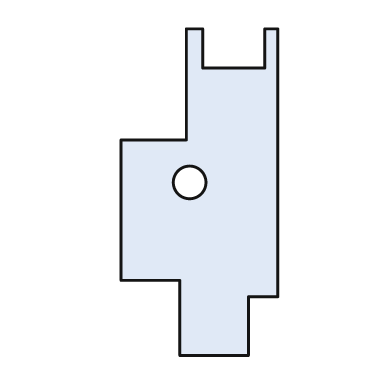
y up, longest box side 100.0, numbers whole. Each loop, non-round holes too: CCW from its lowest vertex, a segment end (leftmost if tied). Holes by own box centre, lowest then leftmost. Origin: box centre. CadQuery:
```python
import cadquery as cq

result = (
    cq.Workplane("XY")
    .moveTo(-6.0, -50.0)
    .lineTo(15.0, -50.0)
    .lineTo(15.0, -32.0)
    .lineTo(24.0, -32.0)
    .lineTo(24.0, 50.0)
    .lineTo(20.0, 50.0)
    .lineTo(20.0, 38.0)
    .lineTo(1.0, 38.0)
    .lineTo(1.0, 50.0)
    .lineTo(-4.0, 50.0)
    .lineTo(-4.0, 16.0)
    .lineTo(-24.0, 16.0)
    .lineTo(-24.0, -27.0)
    .lineTo(-6.0, -27.0)
    .close()
    .moveTo(-3.0, 3.0)
    .circle(5.0)
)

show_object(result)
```